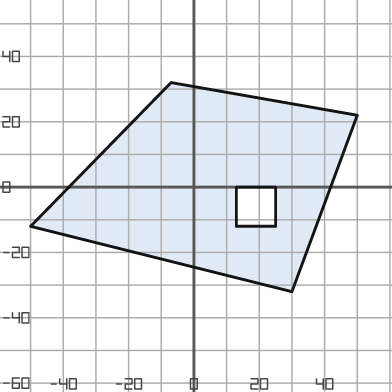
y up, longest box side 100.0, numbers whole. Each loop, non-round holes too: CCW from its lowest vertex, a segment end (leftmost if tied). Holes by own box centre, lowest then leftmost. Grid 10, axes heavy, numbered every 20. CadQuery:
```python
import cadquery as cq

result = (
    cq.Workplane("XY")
    .moveTo(30.0, -32.0)
    .lineTo(50.0, 22.0)
    .lineTo(-7.0, 32.0)
    .lineTo(-50.0, -12.0)
    .close()
    .moveTo(13.0, -12.0)
    .lineTo(25.0, -12.0)
    .lineTo(25.0, 0.0)
    .lineTo(13.0, 0.0)
    .close()
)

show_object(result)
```